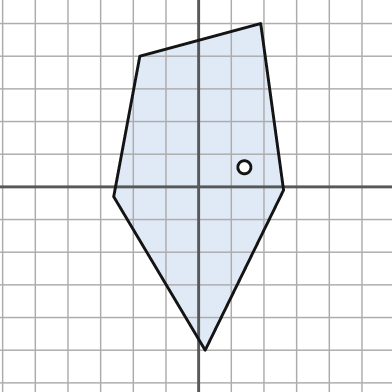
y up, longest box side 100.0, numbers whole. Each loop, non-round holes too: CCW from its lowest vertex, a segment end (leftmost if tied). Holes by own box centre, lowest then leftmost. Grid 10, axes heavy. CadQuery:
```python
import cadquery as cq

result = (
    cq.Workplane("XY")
    .moveTo(2.0, -50.0)
    .lineTo(26.0, -1.0)
    .lineTo(19.0, 50.0)
    .lineTo(-18.0, 40.0)
    .lineTo(-26.0, -3.0)
    .close()
    .moveTo(14.0, 6.0)
    .circle(2.0)
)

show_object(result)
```